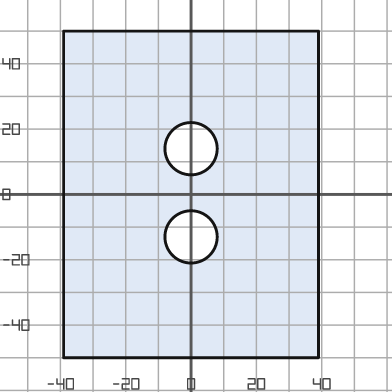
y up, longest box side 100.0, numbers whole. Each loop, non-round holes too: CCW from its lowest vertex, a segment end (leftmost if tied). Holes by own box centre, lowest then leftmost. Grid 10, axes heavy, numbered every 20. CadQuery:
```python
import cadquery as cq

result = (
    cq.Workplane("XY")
    .moveTo(-39.0, -50.0)
    .lineTo(39.0, -50.0)
    .lineTo(39.0, 50.0)
    .lineTo(-39.0, 50.0)
    .close()
    .moveTo(0.0, -13.0)
    .circle(8.0)
    .moveTo(0.0, 14.0)
    .circle(8.0)
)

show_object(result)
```